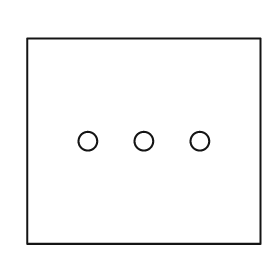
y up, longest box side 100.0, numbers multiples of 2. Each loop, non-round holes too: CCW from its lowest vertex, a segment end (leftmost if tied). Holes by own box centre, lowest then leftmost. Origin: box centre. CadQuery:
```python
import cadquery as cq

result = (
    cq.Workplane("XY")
    .moveTo(-50.0, -44.0)
    .lineTo(50.0, -44.0)
    .lineTo(50.0, 44.0)
    .lineTo(-50.0, 44.0)
    .close()
    .moveTo(-24.0, 0.0)
    .circle(4.0)
    .moveTo(0.0, 0.0)
    .circle(4.0)
    .moveTo(24.0, 0.0)
    .circle(4.0)
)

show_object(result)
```